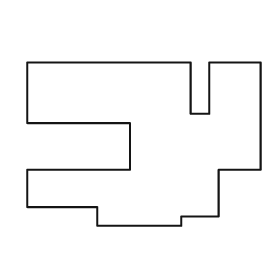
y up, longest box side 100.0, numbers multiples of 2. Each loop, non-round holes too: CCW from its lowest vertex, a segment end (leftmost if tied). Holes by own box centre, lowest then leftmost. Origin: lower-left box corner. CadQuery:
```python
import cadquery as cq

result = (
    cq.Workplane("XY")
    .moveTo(30.0, 0.0)
    .lineTo(66.0, 0.0)
    .lineTo(66.0, 4.0)
    .lineTo(82.0, 4.0)
    .lineTo(82.0, 24.0)
    .lineTo(100.0, 24.0)
    .lineTo(100.0, 70.0)
    .lineTo(78.0, 70.0)
    .lineTo(78.0, 48.0)
    .lineTo(70.0, 48.0)
    .lineTo(70.0, 70.0)
    .lineTo(0.0, 70.0)
    .lineTo(0.0, 44.0)
    .lineTo(44.0, 44.0)
    .lineTo(44.0, 24.0)
    .lineTo(0.0, 24.0)
    .lineTo(0.0, 8.0)
    .lineTo(30.0, 8.0)
    .close()
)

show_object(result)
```